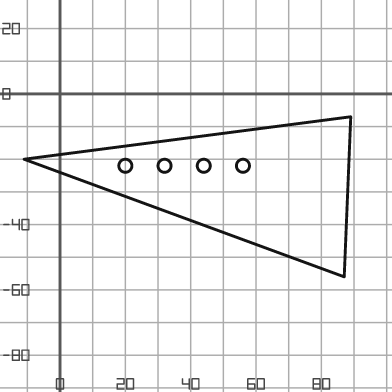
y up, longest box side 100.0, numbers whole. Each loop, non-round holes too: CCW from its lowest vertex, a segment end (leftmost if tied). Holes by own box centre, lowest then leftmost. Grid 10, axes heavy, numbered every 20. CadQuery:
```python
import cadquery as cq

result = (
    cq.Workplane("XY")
    .moveTo(87.0, -56.0)
    .lineTo(89.0, -7.0)
    .lineTo(-11.0, -20.0)
    .close()
    .moveTo(20.0, -22.0)
    .circle(2.0)
    .moveTo(32.0, -22.0)
    .circle(2.0)
    .moveTo(44.0, -22.0)
    .circle(2.0)
    .moveTo(56.0, -22.0)
    .circle(2.0)
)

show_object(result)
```